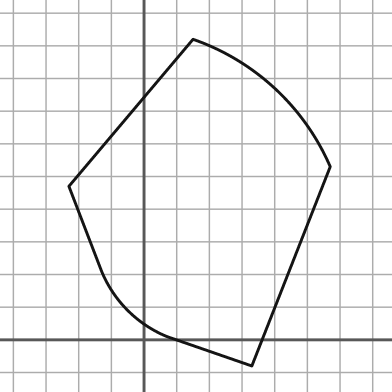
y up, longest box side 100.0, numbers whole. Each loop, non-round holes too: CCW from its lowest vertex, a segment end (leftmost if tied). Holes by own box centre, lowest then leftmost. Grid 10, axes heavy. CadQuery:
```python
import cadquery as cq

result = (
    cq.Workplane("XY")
    .moveTo(33.0, -8.0)
    .lineTo(57.0, 53.0)
    .threePointArc((40.0, 77.0), (15.0, 92.0))
    .lineTo(-23.0, 47.0)
    .lineTo(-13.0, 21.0)
    .threePointArc((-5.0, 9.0), (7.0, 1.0))
    .close()
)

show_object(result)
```